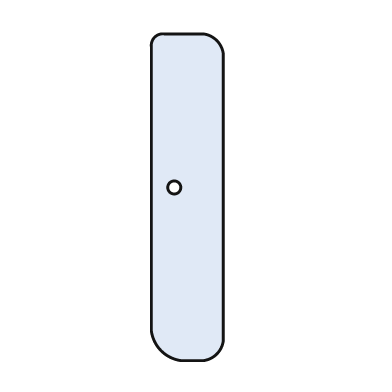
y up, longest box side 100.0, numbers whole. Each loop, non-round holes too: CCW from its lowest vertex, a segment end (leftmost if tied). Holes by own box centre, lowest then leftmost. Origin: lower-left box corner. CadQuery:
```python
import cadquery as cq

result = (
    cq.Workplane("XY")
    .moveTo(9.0, 0.0)
    .lineTo(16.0, 0.0)
    .threePointArc((20.0, 2.0), (22.0, 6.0))
    .lineTo(22.0, 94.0)
    .threePointArc((20.0, 98.0), (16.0, 100.0))
    .lineTo(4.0, 100.0)
    .threePointArc((1.0, 99.0), (0.0, 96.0))
    .lineTo(0.0, 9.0)
    .threePointArc((3.0, 3.0), (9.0, 0.0))
    .close()
    .moveTo(7.0, 53.0)
    .circle(2.0)
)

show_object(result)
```